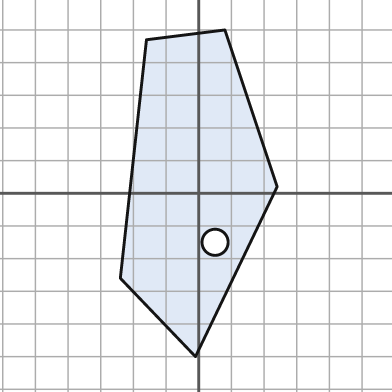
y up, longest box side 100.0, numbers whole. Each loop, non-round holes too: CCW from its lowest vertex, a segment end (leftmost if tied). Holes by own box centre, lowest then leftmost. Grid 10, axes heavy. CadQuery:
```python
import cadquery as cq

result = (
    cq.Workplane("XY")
    .moveTo(-1.0, -50.0)
    .lineTo(24.0, 2.0)
    .lineTo(8.0, 50.0)
    .lineTo(-16.0, 47.0)
    .lineTo(-24.0, -26.0)
    .close()
    .moveTo(5.0, -15.0)
    .circle(4.0)
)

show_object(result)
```